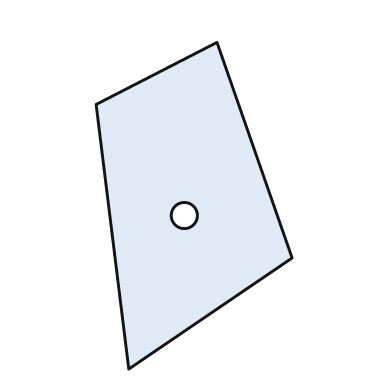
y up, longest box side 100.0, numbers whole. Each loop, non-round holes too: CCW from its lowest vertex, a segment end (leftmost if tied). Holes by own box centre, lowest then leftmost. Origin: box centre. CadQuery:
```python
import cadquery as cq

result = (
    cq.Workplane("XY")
    .moveTo(-20.0, -50.0)
    .lineTo(30.0, -16.0)
    .lineTo(7.0, 50.0)
    .lineTo(-30.0, 31.0)
    .close()
    .moveTo(-3.0, -3.0)
    .circle(4.0)
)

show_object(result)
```